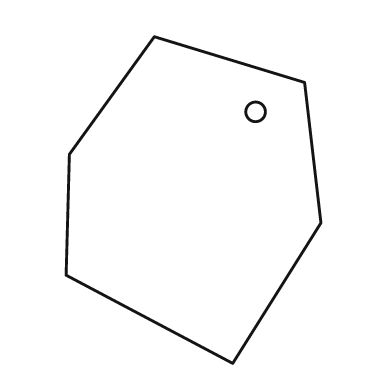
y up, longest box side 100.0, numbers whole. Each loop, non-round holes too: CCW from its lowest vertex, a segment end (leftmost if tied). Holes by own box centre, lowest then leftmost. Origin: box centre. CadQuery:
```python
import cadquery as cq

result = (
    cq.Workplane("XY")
    .moveTo(12.0, -50.0)
    .lineTo(39.0, -7.0)
    .lineTo(34.0, 36.0)
    .lineTo(-12.0, 50.0)
    .lineTo(-38.0, 14.0)
    .lineTo(-39.0, -23.0)
    .close()
    .moveTo(19.0, 27.0)
    .circle(3.0)
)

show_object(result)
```